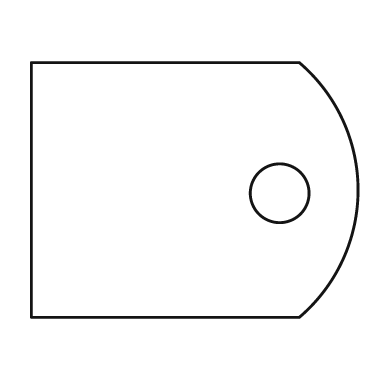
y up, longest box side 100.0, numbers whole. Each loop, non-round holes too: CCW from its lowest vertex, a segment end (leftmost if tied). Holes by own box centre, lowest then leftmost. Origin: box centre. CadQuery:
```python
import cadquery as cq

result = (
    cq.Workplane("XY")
    .moveTo(-50.0, -39.0)
    .lineTo(32.0, -39.0)
    .threePointArc((50.0, 0.0), (32.0, 39.0))
    .lineTo(-50.0, 39.0)
    .close()
    .moveTo(26.0, -1.0)
    .circle(9.0)
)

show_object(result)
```